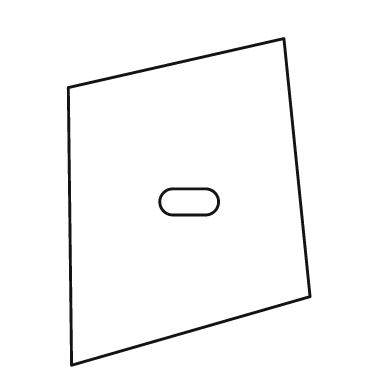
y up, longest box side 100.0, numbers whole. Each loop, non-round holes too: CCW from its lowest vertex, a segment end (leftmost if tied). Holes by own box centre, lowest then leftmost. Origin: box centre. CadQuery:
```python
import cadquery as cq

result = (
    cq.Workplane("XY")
    .moveTo(-36.0, -50.0)
    .lineTo(37.0, -29.0)
    .lineTo(29.0, 50.0)
    .lineTo(-37.0, 35.0)
    .close()
    .moveTo(-5.0, -4.0)
    .lineTo(5.0, -4.0)
    .threePointArc((9.0, 0.0), (5.0, 4.0))
    .lineTo(-5.0, 4.0)
    .threePointArc((-9.0, 0.0), (-5.0, -4.0))
    .close()
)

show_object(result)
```